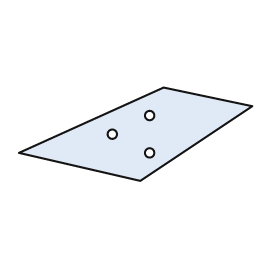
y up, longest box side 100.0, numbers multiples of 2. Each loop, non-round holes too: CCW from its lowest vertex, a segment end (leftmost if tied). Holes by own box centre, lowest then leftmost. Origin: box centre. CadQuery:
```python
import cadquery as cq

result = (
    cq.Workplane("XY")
    .moveTo(2.0, -20.0)
    .lineTo(50.0, 12.0)
    .lineTo(12.0, 20.0)
    .lineTo(-50.0, -8.0)
    .close()
    .moveTo(6.0, -8.0)
    .circle(2.0)
    .moveTo(-10.0, 0.0)
    .circle(2.0)
    .moveTo(6.0, 8.0)
    .circle(2.0)
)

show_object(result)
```